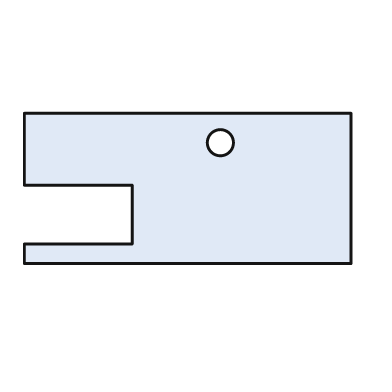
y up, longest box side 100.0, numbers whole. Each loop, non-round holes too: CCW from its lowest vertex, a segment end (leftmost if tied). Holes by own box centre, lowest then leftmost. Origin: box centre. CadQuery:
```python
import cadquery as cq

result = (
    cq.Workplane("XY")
    .moveTo(-50.0, -23.0)
    .lineTo(50.0, -23.0)
    .lineTo(50.0, 23.0)
    .lineTo(-50.0, 23.0)
    .lineTo(-50.0, 1.0)
    .lineTo(-17.0, 1.0)
    .lineTo(-17.0, -17.0)
    .lineTo(-50.0, -17.0)
    .close()
    .moveTo(10.0, 14.0)
    .circle(4.0)
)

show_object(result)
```